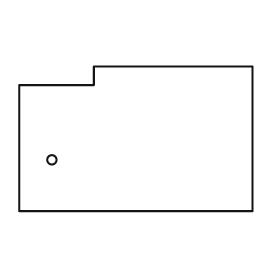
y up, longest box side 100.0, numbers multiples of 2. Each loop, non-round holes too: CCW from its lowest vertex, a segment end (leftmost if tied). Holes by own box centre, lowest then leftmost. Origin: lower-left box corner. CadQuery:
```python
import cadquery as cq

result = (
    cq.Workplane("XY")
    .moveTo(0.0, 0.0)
    .lineTo(100.0, 0.0)
    .lineTo(100.0, 62.0)
    .lineTo(32.0, 62.0)
    .lineTo(32.0, 54.0)
    .lineTo(0.0, 54.0)
    .close()
    .moveTo(14.0, 22.0)
    .circle(2.0)
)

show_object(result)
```